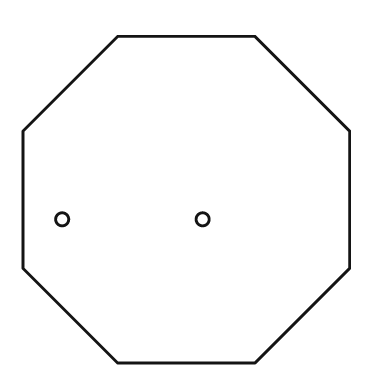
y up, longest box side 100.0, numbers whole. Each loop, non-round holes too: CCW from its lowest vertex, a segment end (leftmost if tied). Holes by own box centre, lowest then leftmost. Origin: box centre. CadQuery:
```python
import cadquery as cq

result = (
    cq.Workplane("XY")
    .moveTo(-21.0, -50.0)
    .lineTo(21.0, -50.0)
    .lineTo(50.0, -21.0)
    .lineTo(50.0, 21.0)
    .lineTo(21.0, 50.0)
    .lineTo(-21.0, 50.0)
    .lineTo(-50.0, 21.0)
    .lineTo(-50.0, -21.0)
    .close()
    .moveTo(-38.0, -6.0)
    .circle(2.0)
    .moveTo(5.0, -6.0)
    .circle(2.0)
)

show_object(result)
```